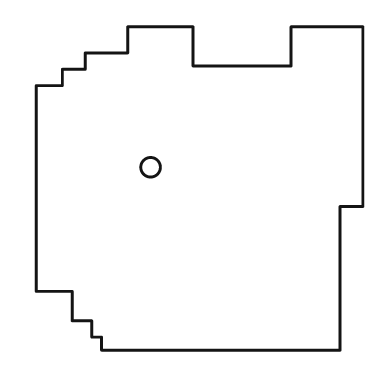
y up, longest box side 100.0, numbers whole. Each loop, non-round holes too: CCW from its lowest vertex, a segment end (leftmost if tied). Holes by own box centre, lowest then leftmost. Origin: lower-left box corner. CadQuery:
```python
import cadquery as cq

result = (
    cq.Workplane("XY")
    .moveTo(20.0, 0.0)
    .lineTo(93.0, 0.0)
    .lineTo(93.0, 44.0)
    .lineTo(100.0, 44.0)
    .lineTo(100.0, 99.0)
    .lineTo(78.0, 99.0)
    .lineTo(78.0, 87.0)
    .lineTo(48.0, 87.0)
    .lineTo(48.0, 99.0)
    .lineTo(28.0, 99.0)
    .lineTo(28.0, 91.0)
    .lineTo(15.0, 91.0)
    .lineTo(15.0, 86.0)
    .lineTo(8.0, 86.0)
    .lineTo(8.0, 81.0)
    .lineTo(0.0, 81.0)
    .lineTo(0.0, 18.0)
    .lineTo(11.0, 18.0)
    .lineTo(11.0, 9.0)
    .lineTo(17.0, 9.0)
    .lineTo(17.0, 4.0)
    .lineTo(20.0, 4.0)
    .close()
    .moveTo(35.0, 56.0)
    .circle(3.0)
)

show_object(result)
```